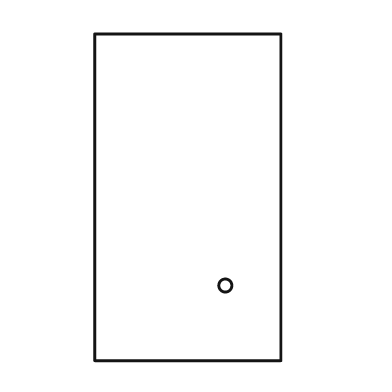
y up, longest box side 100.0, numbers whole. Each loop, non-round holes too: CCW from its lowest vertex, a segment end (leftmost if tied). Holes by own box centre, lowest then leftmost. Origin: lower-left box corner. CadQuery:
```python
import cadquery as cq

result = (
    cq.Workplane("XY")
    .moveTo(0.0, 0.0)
    .lineTo(57.0, 0.0)
    .lineTo(57.0, 100.0)
    .lineTo(0.0, 100.0)
    .close()
    .moveTo(40.0, 23.0)
    .circle(2.0)
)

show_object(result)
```